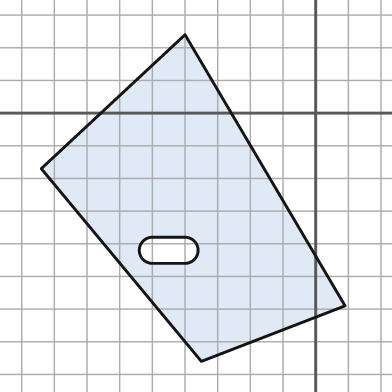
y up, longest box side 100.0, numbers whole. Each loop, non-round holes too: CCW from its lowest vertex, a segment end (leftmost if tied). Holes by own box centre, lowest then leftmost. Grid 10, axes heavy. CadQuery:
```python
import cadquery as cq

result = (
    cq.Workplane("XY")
    .moveTo(-35.0, -76.0)
    .lineTo(9.0, -59.0)
    .lineTo(-40.0, 24.0)
    .lineTo(-84.0, -17.0)
    .close()
    .moveTo(-50.0, -46.0)
    .lineTo(-40.0, -46.0)
    .threePointArc((-36.0, -42.0), (-40.0, -38.0))
    .lineTo(-50.0, -38.0)
    .threePointArc((-54.0, -42.0), (-50.0, -46.0))
    .close()
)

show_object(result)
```